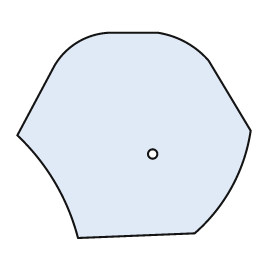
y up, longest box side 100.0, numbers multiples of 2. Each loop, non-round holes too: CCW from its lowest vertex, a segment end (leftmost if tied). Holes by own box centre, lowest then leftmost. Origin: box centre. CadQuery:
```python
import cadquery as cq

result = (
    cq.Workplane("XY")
    .moveTo(-24.0, -44.0)
    .lineTo(26.0, -42.0)
    .threePointArc((42.0, -22.0), (50.0, 2.0))
    .lineTo(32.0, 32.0)
    .threePointArc((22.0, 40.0), (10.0, 44.0))
    .lineTo(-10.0, 44.0)
    .threePointArc((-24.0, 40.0), (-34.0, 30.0))
    .lineTo(-50.0, 0.0)
    .threePointArc((-34.0, -20.0), (-24.0, -44.0))
    .close()
    .moveTo(8.0, -8.0)
    .circle(2.0)
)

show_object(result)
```